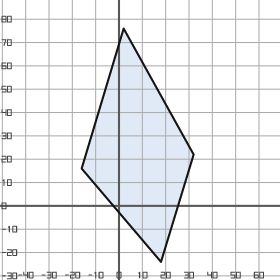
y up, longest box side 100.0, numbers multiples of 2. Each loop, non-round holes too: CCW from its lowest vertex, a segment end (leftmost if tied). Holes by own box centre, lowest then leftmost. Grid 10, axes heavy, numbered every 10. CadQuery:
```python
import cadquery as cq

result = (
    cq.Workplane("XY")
    .moveTo(18.0, -24.0)
    .lineTo(32.0, 22.0)
    .lineTo(2.0, 76.0)
    .lineTo(-16.0, 16.0)
    .close()
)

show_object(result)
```